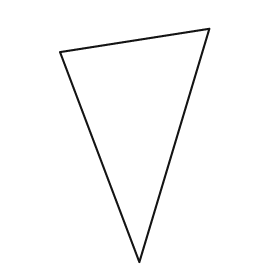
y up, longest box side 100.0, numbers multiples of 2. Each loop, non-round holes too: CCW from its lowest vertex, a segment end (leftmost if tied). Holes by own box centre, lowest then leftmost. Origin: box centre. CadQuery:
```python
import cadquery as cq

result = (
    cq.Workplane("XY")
    .moveTo(2.0, -50.0)
    .lineTo(32.0, 50.0)
    .lineTo(-32.0, 40.0)
    .close()
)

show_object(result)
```